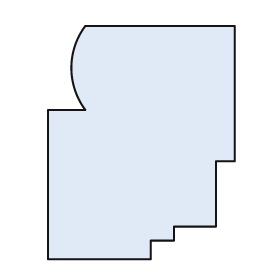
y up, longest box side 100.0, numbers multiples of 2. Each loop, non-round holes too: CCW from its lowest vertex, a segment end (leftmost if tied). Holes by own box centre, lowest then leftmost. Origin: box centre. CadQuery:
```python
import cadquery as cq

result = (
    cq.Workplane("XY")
    .moveTo(-40.0, -50.0)
    .lineTo(4.0, -50.0)
    .lineTo(4.0, -42.0)
    .lineTo(14.0, -42.0)
    .lineTo(14.0, -36.0)
    .lineTo(32.0, -36.0)
    .lineTo(32.0, -8.0)
    .lineTo(40.0, -8.0)
    .lineTo(40.0, 50.0)
    .lineTo(-24.0, 50.0)
    .threePointArc((-30.0, 32.0), (-24.0, 14.0))
    .lineTo(-40.0, 14.0)
    .close()
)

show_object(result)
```